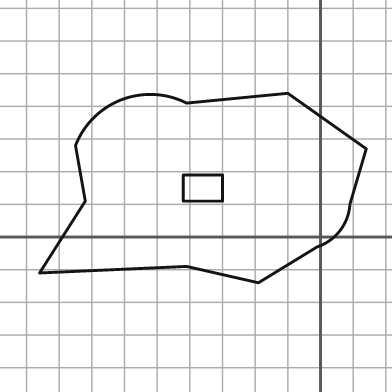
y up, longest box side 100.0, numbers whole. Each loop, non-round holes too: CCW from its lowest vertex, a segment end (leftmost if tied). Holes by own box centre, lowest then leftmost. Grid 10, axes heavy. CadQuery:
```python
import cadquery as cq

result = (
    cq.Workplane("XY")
    .moveTo(-19.0, -14.0)
    .lineTo(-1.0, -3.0)
    .threePointArc((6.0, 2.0), (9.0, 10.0))
    .lineTo(14.0, 27.0)
    .lineTo(-10.0, 44.0)
    .lineTo(-41.0, 41.0)
    .threePointArc((-61.0, 42.0), (-75.0, 28.0))
    .lineTo(-72.0, 11.0)
    .lineTo(-86.0, -11.0)
    .lineTo(-41.0, -9.0)
    .close()
    .moveTo(-42.0, 11.0)
    .lineTo(-30.0, 11.0)
    .lineTo(-30.0, 19.0)
    .lineTo(-42.0, 19.0)
    .close()
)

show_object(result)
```